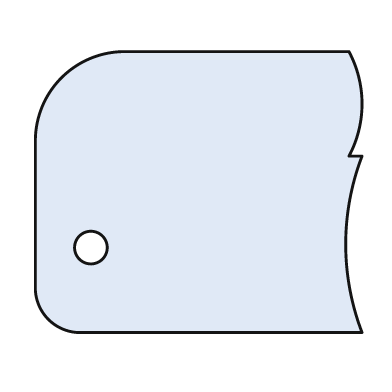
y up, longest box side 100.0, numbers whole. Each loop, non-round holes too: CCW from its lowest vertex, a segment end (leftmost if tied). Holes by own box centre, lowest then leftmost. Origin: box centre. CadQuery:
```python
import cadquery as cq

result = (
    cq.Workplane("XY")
    .moveTo(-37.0, -43.0)
    .lineTo(50.0, -43.0)
    .threePointArc((45.0, -16.0), (50.0, 11.0))
    .lineTo(46.0, 11.0)
    .threePointArc((50.0, 27.0), (46.0, 43.0))
    .lineTo(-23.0, 43.0)
    .threePointArc((-42.0, 35.0), (-50.0, 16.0))
    .lineTo(-50.0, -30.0)
    .threePointArc((-46.0, -39.0), (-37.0, -43.0))
    .close()
    .moveTo(-33.0, -17.0)
    .circle(5.0)
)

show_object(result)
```